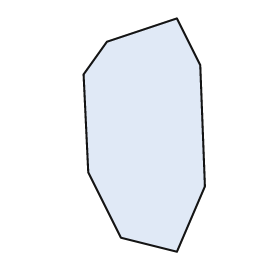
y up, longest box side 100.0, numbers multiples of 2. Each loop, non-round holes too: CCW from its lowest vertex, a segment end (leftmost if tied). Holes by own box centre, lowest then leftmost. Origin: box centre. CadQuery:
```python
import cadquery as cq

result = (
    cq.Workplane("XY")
    .moveTo(14.0, -50.0)
    .lineTo(26.0, -22.0)
    .lineTo(24.0, 30.0)
    .lineTo(14.0, 50.0)
    .lineTo(-16.0, 40.0)
    .lineTo(-26.0, 26.0)
    .lineTo(-24.0, -16.0)
    .lineTo(-10.0, -44.0)
    .close()
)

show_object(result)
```